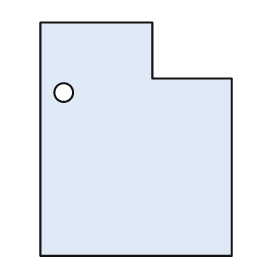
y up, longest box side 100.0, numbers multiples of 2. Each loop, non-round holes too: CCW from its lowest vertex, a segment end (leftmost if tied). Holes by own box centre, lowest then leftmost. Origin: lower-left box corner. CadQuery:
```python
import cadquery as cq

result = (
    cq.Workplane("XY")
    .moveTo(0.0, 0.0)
    .lineTo(82.0, 0.0)
    .lineTo(82.0, 76.0)
    .lineTo(48.0, 76.0)
    .lineTo(48.0, 100.0)
    .lineTo(0.0, 100.0)
    .close()
    .moveTo(10.0, 70.0)
    .circle(4.0)
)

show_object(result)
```